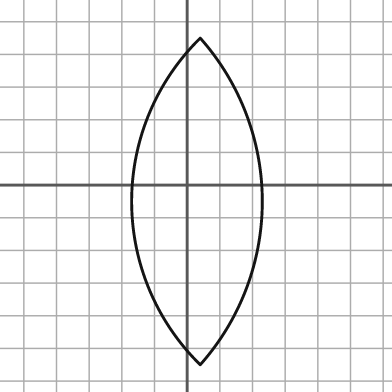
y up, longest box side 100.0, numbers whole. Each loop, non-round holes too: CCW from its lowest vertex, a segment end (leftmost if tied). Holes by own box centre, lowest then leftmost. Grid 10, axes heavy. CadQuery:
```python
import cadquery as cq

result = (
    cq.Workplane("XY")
    .moveTo(4.0, -55.0)
    .threePointArc((23.0, -5.0), (4.0, 45.0))
    .threePointArc((-17.0, -5.0), (4.0, -55.0))
    .close()
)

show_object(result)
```